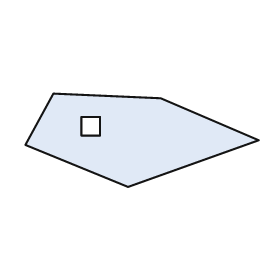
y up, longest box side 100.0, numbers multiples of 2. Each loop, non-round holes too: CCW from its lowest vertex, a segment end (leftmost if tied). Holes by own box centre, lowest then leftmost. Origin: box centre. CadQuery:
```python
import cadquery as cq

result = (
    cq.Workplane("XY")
    .moveTo(-6.0, -20.0)
    .lineTo(50.0, 0.0)
    .lineTo(8.0, 18.0)
    .lineTo(-38.0, 20.0)
    .lineTo(-50.0, -2.0)
    .close()
    .moveTo(-26.0, 2.0)
    .lineTo(-18.0, 2.0)
    .lineTo(-18.0, 10.0)
    .lineTo(-26.0, 10.0)
    .close()
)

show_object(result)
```